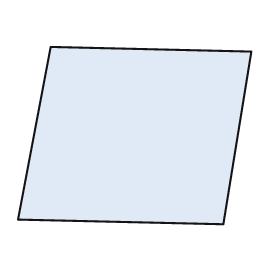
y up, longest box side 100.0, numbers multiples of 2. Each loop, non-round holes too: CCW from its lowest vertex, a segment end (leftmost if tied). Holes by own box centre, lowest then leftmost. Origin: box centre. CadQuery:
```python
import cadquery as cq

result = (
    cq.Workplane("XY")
    .moveTo(38.0, -38.0)
    .lineTo(50.0, 36.0)
    .lineTo(-36.0, 38.0)
    .lineTo(-50.0, -36.0)
    .close()
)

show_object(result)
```